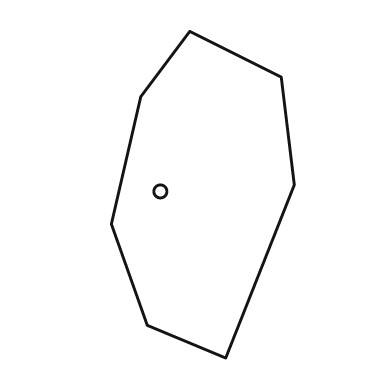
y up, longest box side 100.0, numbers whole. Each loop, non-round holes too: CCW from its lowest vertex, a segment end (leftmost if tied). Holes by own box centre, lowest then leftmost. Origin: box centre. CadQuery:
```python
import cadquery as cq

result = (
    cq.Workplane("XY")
    .moveTo(7.0, -50.0)
    .lineTo(28.0, 3.0)
    .lineTo(24.0, 36.0)
    .lineTo(-4.0, 50.0)
    .lineTo(-19.0, 30.0)
    .lineTo(-28.0, -9.0)
    .lineTo(-17.0, -40.0)
    .close()
    .moveTo(-13.0, 1.0)
    .circle(2.0)
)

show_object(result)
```